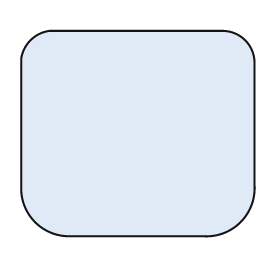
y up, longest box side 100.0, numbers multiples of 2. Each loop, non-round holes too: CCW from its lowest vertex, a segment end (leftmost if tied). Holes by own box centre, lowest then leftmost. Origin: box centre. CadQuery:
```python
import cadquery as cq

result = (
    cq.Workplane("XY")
    .moveTo(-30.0, -44.0)
    .lineTo(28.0, -44.0)
    .threePointArc((44.0, -38.0), (50.0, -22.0))
    .lineTo(50.0, 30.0)
    .threePointArc((46.0, 40.0), (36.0, 44.0))
    .lineTo(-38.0, 44.0)
    .threePointArc((-46.0, 40.0), (-50.0, 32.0))
    .lineTo(-50.0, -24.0)
    .threePointArc((-44.0, -38.0), (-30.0, -44.0))
    .close()
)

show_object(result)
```